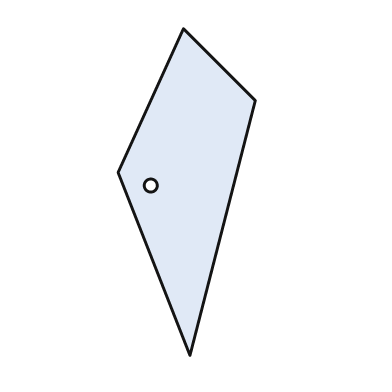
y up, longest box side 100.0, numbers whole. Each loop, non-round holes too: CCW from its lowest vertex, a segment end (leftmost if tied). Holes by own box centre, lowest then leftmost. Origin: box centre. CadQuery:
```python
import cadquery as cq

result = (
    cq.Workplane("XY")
    .moveTo(1.0, -50.0)
    .lineTo(21.0, 28.0)
    .lineTo(-1.0, 50.0)
    .lineTo(-21.0, 6.0)
    .close()
    .moveTo(-11.0, 2.0)
    .circle(2.0)
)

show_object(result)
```